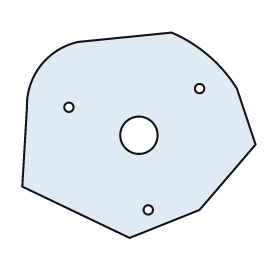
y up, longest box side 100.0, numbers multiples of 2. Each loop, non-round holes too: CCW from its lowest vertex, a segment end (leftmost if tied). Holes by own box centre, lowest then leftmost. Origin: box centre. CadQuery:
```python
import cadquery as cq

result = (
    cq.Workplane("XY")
    .moveTo(-4.0, -44.0)
    .lineTo(26.0, -32.0)
    .lineTo(50.0, -4.0)
    .lineTo(42.0, 20.0)
    .threePointArc((30.0, 34.0), (14.0, 44.0))
    .lineTo(-26.0, 40.0)
    .threePointArc((-42.0, 30.0), (-48.0, 12.0))
    .lineTo(-50.0, -22.0)
    .close()
    .moveTo(4.0, -32.0)
    .circle(2.0)
    .moveTo(0.0, 0.0)
    .circle(8.0)
    .moveTo(-30.0, 12.0)
    .circle(2.0)
    .moveTo(26.0, 20.0)
    .circle(2.0)
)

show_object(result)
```